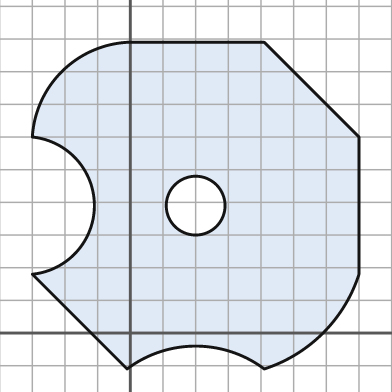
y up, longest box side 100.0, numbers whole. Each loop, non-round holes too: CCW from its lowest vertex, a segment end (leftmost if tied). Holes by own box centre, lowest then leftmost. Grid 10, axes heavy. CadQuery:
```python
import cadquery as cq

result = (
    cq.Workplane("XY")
    .moveTo(-1.0, -11.0)
    .threePointArc((20.0, -4.0), (41.0, -11.0))
    .threePointArc((59.0, 0.0), (70.0, 18.0))
    .lineTo(70.0, 60.0)
    .lineTo(41.0, 89.0)
    .lineTo(-1.0, 89.0)
    .threePointArc((-21.0, 80.0), (-30.0, 60.0))
    .threePointArc((-11.0, 39.0), (-30.0, 18.0))
    .close()
    .moveTo(20.0, 39.0)
    .circle(9.0)
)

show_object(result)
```